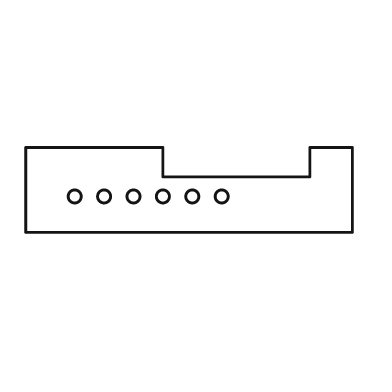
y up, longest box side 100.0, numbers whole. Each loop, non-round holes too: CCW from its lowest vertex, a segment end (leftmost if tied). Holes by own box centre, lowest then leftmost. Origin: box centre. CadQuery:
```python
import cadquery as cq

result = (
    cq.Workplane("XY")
    .moveTo(-50.0, -13.0)
    .lineTo(50.0, -13.0)
    .lineTo(50.0, 13.0)
    .lineTo(37.0, 13.0)
    .lineTo(37.0, 4.0)
    .lineTo(-8.0, 4.0)
    .lineTo(-8.0, 13.0)
    .lineTo(-50.0, 13.0)
    .close()
    .moveTo(-35.0, -2.0)
    .circle(2.0)
    .moveTo(-26.0, -2.0)
    .circle(2.0)
    .moveTo(-17.0, -2.0)
    .circle(2.0)
    .moveTo(-8.0, -2.0)
    .circle(2.0)
    .moveTo(1.0, -2.0)
    .circle(2.0)
    .moveTo(10.0, -2.0)
    .circle(2.0)
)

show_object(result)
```